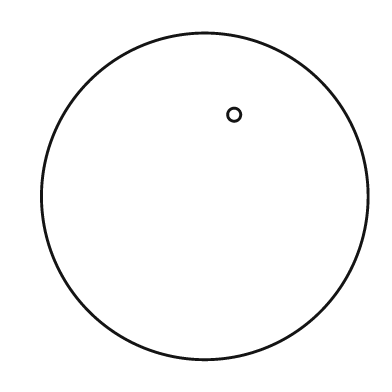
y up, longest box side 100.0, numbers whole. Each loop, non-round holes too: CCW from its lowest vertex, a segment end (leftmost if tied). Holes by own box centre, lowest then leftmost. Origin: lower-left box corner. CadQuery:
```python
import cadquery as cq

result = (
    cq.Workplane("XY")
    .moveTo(50.0, 50.0)
    .circle(50.0)
    .moveTo(59.0, 75.0)
    .circle(2.0)
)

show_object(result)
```